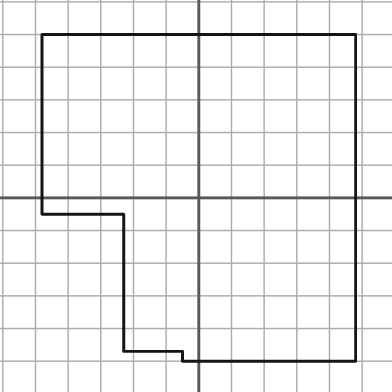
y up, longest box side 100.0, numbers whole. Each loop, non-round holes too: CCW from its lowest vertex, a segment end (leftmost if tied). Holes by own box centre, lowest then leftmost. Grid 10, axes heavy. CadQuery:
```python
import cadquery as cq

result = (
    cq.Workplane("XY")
    .moveTo(-5.0, -50.0)
    .lineTo(48.0, -50.0)
    .lineTo(48.0, 50.0)
    .lineTo(-48.0, 50.0)
    .lineTo(-48.0, -5.0)
    .lineTo(-23.0, -5.0)
    .lineTo(-23.0, -47.0)
    .lineTo(-5.0, -47.0)
    .close()
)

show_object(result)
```